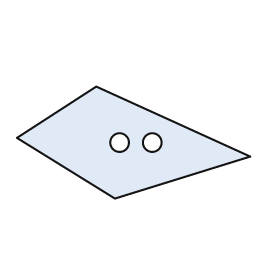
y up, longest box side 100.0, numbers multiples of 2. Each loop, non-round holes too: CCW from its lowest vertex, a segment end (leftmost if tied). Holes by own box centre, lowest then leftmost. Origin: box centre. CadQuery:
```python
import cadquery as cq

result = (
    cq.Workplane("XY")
    .moveTo(-8.0, -24.0)
    .lineTo(50.0, -6.0)
    .lineTo(-16.0, 24.0)
    .lineTo(-50.0, 2.0)
    .close()
    .moveTo(-6.0, 0.0)
    .circle(4.0)
    .moveTo(8.0, 0.0)
    .circle(4.0)
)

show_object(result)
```